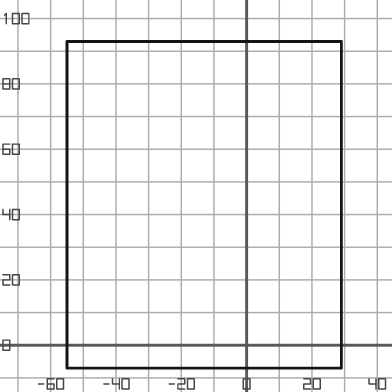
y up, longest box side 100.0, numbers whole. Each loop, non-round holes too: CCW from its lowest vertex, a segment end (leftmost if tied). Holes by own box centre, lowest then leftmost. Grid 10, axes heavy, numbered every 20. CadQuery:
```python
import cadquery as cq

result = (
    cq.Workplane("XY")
    .moveTo(-55.0, -7.0)
    .lineTo(29.0, -7.0)
    .lineTo(29.0, 93.0)
    .lineTo(-55.0, 93.0)
    .close()
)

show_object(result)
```